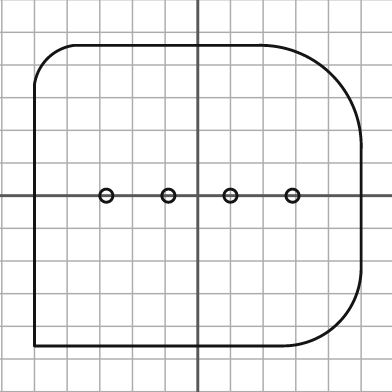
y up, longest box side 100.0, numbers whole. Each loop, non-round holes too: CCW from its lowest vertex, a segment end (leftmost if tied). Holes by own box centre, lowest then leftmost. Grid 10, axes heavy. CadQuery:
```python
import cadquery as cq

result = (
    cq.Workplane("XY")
    .moveTo(-50.0, -46.0)
    .lineTo(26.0, -46.0)
    .threePointArc((43.0, -39.0), (50.0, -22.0))
    .lineTo(50.0, 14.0)
    .threePointArc((41.0, 37.0), (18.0, 46.0))
    .lineTo(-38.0, 46.0)
    .threePointArc((-46.0, 42.0), (-50.0, 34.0))
    .close()
    .moveTo(-28.0, 0.0)
    .circle(2.0)
    .moveTo(-9.0, 0.0)
    .circle(2.0)
    .moveTo(10.0, 0.0)
    .circle(2.0)
    .moveTo(29.0, 0.0)
    .circle(2.0)
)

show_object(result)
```